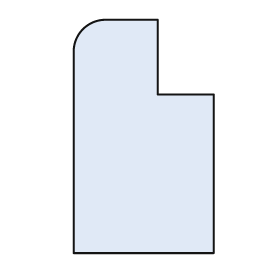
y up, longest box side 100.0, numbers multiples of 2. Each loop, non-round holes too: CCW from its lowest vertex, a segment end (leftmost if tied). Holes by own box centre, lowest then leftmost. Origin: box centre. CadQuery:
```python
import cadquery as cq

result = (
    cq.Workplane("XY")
    .moveTo(-30.0, -50.0)
    .lineTo(30.0, -50.0)
    .lineTo(30.0, 18.0)
    .lineTo(6.0, 18.0)
    .lineTo(6.0, 50.0)
    .lineTo(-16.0, 50.0)
    .threePointArc((-26.0, 46.0), (-30.0, 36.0))
    .close()
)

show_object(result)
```